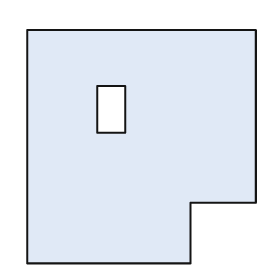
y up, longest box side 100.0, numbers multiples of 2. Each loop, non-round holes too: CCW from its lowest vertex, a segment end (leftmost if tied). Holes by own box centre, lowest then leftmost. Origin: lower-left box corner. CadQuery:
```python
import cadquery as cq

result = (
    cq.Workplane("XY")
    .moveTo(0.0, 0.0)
    .lineTo(70.0, 0.0)
    .lineTo(70.0, 26.0)
    .lineTo(98.0, 26.0)
    .lineTo(98.0, 100.0)
    .lineTo(0.0, 100.0)
    .close()
    .moveTo(30.0, 56.0)
    .lineTo(42.0, 56.0)
    .lineTo(42.0, 76.0)
    .lineTo(30.0, 76.0)
    .close()
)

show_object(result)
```